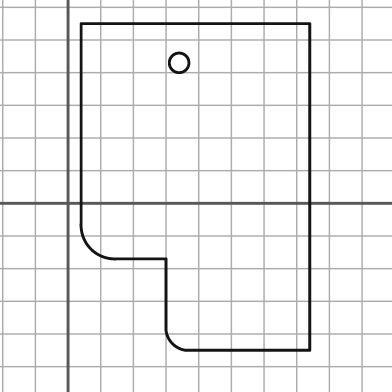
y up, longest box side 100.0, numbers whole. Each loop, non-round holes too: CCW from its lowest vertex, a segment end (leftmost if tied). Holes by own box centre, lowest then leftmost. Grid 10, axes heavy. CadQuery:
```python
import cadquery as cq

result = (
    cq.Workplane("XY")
    .moveTo(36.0, -45.0)
    .lineTo(74.0, -45.0)
    .lineTo(74.0, 55.0)
    .lineTo(4.0, 55.0)
    .lineTo(4.0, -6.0)
    .threePointArc((7.0, -14.0), (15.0, -17.0))
    .lineTo(30.0, -17.0)
    .lineTo(30.0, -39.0)
    .threePointArc((32.0, -43.0), (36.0, -45.0))
    .close()
    .moveTo(34.0, 43.0)
    .circle(3.0)
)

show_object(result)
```